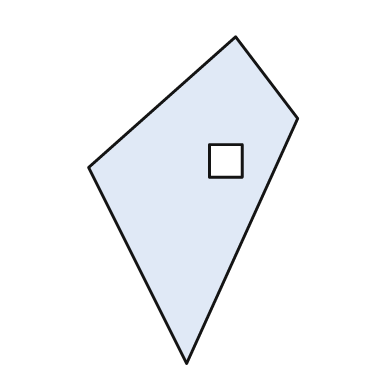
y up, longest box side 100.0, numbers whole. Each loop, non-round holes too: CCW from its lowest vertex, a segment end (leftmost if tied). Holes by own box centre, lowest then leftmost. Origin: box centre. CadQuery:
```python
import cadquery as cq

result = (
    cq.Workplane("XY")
    .moveTo(-2.0, -50.0)
    .lineTo(32.0, 25.0)
    .lineTo(13.0, 50.0)
    .lineTo(-32.0, 10.0)
    .close()
    .moveTo(5.0, 7.0)
    .lineTo(15.0, 7.0)
    .lineTo(15.0, 17.0)
    .lineTo(5.0, 17.0)
    .close()
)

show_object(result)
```